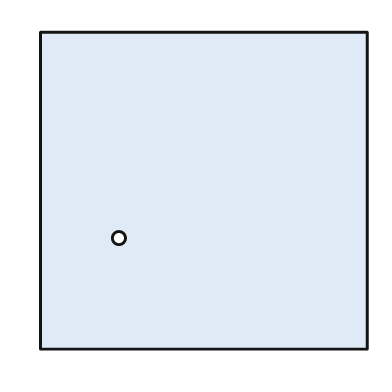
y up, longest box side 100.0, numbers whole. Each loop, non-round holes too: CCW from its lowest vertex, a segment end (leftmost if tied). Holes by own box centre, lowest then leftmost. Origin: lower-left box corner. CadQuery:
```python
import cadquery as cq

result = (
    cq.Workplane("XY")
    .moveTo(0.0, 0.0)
    .lineTo(100.0, 0.0)
    .lineTo(100.0, 97.0)
    .lineTo(0.0, 97.0)
    .close()
    .moveTo(24.0, 34.0)
    .circle(2.0)
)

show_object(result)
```